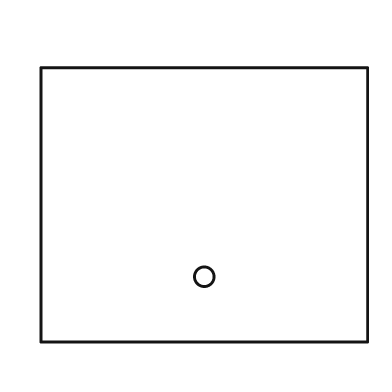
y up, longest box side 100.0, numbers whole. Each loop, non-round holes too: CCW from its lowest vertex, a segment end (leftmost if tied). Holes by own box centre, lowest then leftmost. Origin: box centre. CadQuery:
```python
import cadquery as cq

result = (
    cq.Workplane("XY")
    .moveTo(-50.0, -42.0)
    .lineTo(50.0, -42.0)
    .lineTo(50.0, 42.0)
    .lineTo(-50.0, 42.0)
    .close()
    .moveTo(0.0, -22.0)
    .circle(3.0)
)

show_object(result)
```